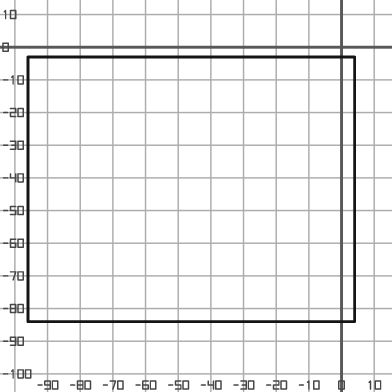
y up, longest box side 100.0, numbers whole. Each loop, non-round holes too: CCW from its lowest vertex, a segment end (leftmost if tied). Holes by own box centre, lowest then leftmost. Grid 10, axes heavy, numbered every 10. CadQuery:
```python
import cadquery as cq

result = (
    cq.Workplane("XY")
    .moveTo(-96.0, -84.0)
    .lineTo(4.0, -84.0)
    .lineTo(4.0, -3.0)
    .lineTo(-96.0, -3.0)
    .close()
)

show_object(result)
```